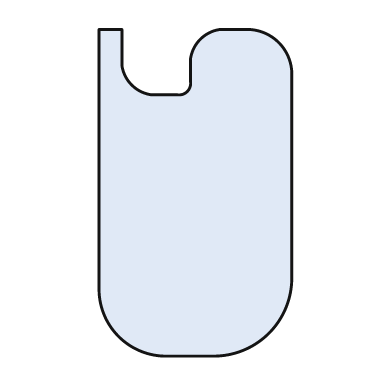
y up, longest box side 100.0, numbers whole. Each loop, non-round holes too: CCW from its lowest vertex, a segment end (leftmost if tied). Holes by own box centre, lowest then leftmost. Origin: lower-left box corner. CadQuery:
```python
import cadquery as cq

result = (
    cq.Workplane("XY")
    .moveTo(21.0, 0.0)
    .lineTo(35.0, 0.0)
    .threePointArc((52.0, 7.0), (59.0, 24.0))
    .lineTo(59.0, 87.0)
    .threePointArc((55.0, 96.0), (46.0, 100.0))
    .lineTo(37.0, 100.0)
    .threePointArc((31.0, 97.0), (28.0, 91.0))
    .lineTo(28.0, 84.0)
    .threePointArc((27.0, 81.0), (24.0, 80.0))
    .lineTo(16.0, 80.0)
    .threePointArc((10.0, 83.0), (7.0, 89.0))
    .lineTo(7.0, 100.0)
    .lineTo(0.0, 100.0)
    .lineTo(0.0, 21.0)
    .threePointArc((6.0, 6.0), (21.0, 0.0))
    .close()
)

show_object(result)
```